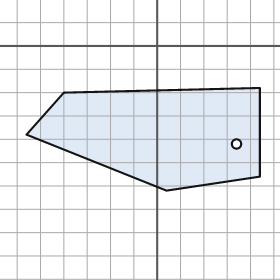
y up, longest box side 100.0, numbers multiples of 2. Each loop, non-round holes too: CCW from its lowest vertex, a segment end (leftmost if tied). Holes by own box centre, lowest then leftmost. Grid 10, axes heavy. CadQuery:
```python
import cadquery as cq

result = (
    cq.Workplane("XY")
    .moveTo(4.0, -62.0)
    .lineTo(44.0, -56.0)
    .lineTo(44.0, -18.0)
    .lineTo(-40.0, -20.0)
    .lineTo(-56.0, -38.0)
    .close()
    .moveTo(34.0, -42.0)
    .circle(2.0)
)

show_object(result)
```